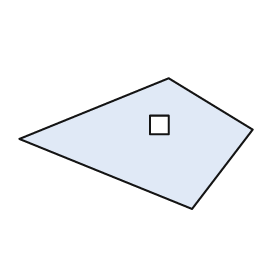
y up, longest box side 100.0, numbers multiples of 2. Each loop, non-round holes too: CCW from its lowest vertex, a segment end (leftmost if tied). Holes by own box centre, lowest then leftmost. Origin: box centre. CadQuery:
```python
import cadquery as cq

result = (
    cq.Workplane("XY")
    .moveTo(24.0, -28.0)
    .lineTo(50.0, 6.0)
    .lineTo(14.0, 28.0)
    .lineTo(-50.0, 2.0)
    .close()
    .moveTo(6.0, 4.0)
    .lineTo(14.0, 4.0)
    .lineTo(14.0, 12.0)
    .lineTo(6.0, 12.0)
    .close()
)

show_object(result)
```